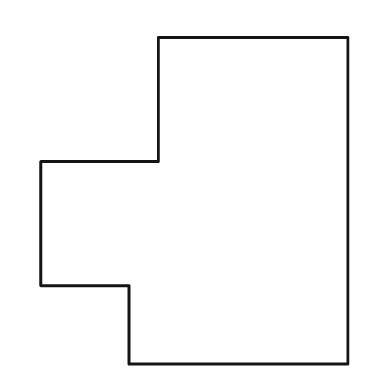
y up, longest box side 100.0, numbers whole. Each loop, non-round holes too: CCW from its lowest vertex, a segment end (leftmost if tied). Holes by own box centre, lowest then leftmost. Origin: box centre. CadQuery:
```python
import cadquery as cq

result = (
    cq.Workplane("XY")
    .moveTo(-20.0, -50.0)
    .lineTo(47.0, -50.0)
    .lineTo(47.0, 50.0)
    .lineTo(-11.0, 50.0)
    .lineTo(-11.0, 12.0)
    .lineTo(-47.0, 12.0)
    .lineTo(-47.0, -26.0)
    .lineTo(-20.0, -26.0)
    .close()
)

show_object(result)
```